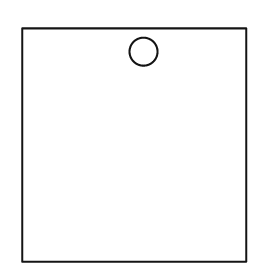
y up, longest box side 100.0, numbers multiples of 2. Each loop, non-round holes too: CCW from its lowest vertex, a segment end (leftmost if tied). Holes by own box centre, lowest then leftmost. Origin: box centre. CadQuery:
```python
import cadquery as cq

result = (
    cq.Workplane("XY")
    .moveTo(-48.0, -50.0)
    .lineTo(48.0, -50.0)
    .lineTo(48.0, 50.0)
    .lineTo(-48.0, 50.0)
    .close()
    .moveTo(4.0, 40.0)
    .circle(6.0)
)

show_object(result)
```